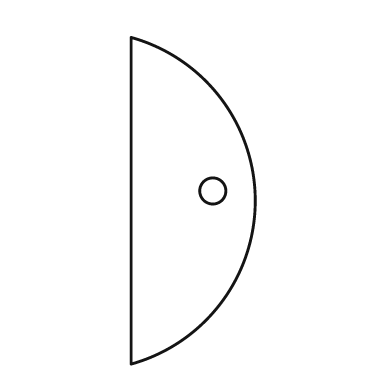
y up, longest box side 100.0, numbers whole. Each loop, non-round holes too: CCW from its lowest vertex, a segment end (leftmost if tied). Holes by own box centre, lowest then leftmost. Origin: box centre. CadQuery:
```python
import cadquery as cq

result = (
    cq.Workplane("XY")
    .moveTo(-19.0, -50.0)
    .threePointArc((19.0, 0.0), (-19.0, 50.0))
    .close()
    .moveTo(6.0, 3.0)
    .circle(4.0)
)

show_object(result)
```